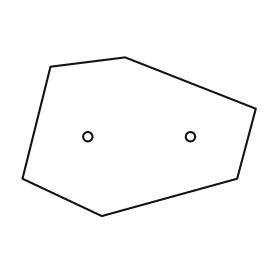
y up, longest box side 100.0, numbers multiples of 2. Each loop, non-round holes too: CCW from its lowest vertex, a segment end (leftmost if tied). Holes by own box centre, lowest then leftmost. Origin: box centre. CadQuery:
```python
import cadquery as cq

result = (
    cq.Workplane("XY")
    .moveTo(-16.0, -34.0)
    .lineTo(42.0, -18.0)
    .lineTo(50.0, 12.0)
    .lineTo(-6.0, 34.0)
    .lineTo(-38.0, 30.0)
    .lineTo(-50.0, -18.0)
    .close()
    .moveTo(-22.0, 0.0)
    .circle(2.0)
    .moveTo(22.0, 0.0)
    .circle(2.0)
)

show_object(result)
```